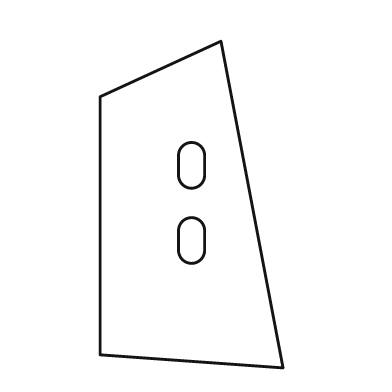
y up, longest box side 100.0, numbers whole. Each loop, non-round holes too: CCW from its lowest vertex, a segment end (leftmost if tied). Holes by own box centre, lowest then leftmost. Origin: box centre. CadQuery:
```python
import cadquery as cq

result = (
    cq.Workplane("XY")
    .moveTo(28.0, -50.0)
    .lineTo(9.0, 50.0)
    .lineTo(-28.0, 33.0)
    .lineTo(-28.0, -46.0)
    .close()
    .moveTo(-4.0, -14.0)
    .threePointArc((0.0, -18.0), (4.0, -14.0))
    .lineTo(4.0, -8.0)
    .threePointArc((0.0, -4.0), (-4.0, -8.0))
    .close()
    .moveTo(-4.0, 9.0)
    .threePointArc((0.0, 5.0), (4.0, 9.0))
    .lineTo(4.0, 15.0)
    .threePointArc((0.0, 19.0), (-4.0, 15.0))
    .close()
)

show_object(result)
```